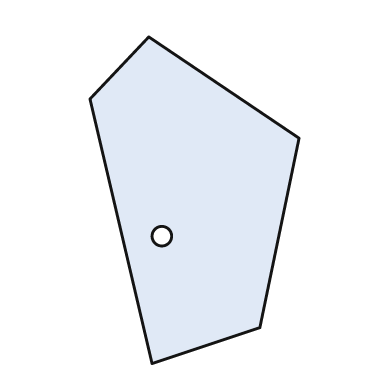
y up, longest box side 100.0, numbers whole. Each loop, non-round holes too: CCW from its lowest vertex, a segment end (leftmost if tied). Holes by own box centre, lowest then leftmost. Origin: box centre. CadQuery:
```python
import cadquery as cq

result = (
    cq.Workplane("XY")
    .moveTo(-13.0, -50.0)
    .lineTo(20.0, -39.0)
    .lineTo(32.0, 19.0)
    .lineTo(-14.0, 50.0)
    .lineTo(-32.0, 31.0)
    .close()
    .moveTo(-10.0, -11.0)
    .circle(3.0)
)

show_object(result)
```